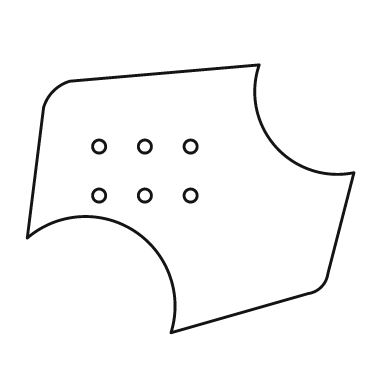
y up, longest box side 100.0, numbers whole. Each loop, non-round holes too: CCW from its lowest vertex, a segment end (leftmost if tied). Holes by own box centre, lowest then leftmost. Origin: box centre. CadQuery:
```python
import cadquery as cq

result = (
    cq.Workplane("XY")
    .moveTo(-6.0, -41.0)
    .lineTo(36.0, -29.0)
    .threePointArc((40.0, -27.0), (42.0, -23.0))
    .lineTo(50.0, 8.0)
    .threePointArc((26.0, 16.0), (21.0, 41.0))
    .lineTo(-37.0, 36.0)
    .threePointArc((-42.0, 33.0), (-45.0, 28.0))
    .lineTo(-50.0, -12.0)
    .threePointArc((-17.0, -10.0), (-6.0, -41.0))
    .close()
    .moveTo(-28.0, 1.0)
    .circle(2.0)
    .moveTo(-14.0, 1.0)
    .circle(2.0)
    .moveTo(0.0, 1.0)
    .circle(2.0)
    .moveTo(-28.0, 16.0)
    .circle(2.0)
    .moveTo(-14.0, 16.0)
    .circle(2.0)
    .moveTo(0.0, 16.0)
    .circle(2.0)
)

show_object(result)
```